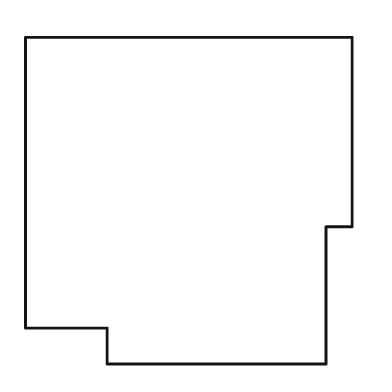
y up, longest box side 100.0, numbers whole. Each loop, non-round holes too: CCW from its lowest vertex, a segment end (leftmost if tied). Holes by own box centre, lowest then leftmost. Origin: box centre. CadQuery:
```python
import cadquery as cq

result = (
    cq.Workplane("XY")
    .moveTo(-25.0, -50.0)
    .lineTo(42.0, -50.0)
    .lineTo(42.0, -8.0)
    .lineTo(50.0, -8.0)
    .lineTo(50.0, 50.0)
    .lineTo(-50.0, 50.0)
    .lineTo(-50.0, -39.0)
    .lineTo(-25.0, -39.0)
    .close()
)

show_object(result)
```